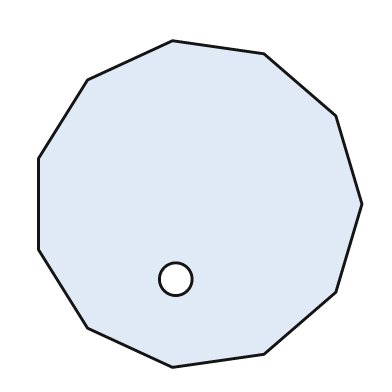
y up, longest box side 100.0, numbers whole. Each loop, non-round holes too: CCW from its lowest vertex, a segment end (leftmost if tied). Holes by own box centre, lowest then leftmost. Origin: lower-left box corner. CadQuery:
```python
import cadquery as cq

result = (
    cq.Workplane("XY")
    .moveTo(41.0, 0.0)
    .lineTo(69.0, 4.0)
    .lineTo(91.0, 23.0)
    .lineTo(99.0, 50.0)
    .lineTo(91.0, 77.0)
    .lineTo(69.0, 96.0)
    .lineTo(41.0, 100.0)
    .lineTo(15.0, 88.0)
    .lineTo(0.0, 64.0)
    .lineTo(0.0, 36.0)
    .lineTo(15.0, 12.0)
    .close()
    .moveTo(42.0, 27.0)
    .circle(5.0)
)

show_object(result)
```